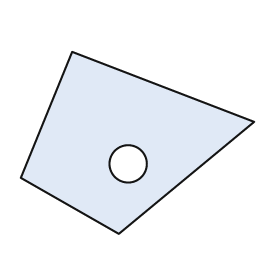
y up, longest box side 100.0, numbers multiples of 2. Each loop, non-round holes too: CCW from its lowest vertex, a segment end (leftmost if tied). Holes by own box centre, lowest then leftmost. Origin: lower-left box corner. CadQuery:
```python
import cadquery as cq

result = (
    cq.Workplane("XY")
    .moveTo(42.0, 0.0)
    .lineTo(100.0, 48.0)
    .lineTo(22.0, 78.0)
    .lineTo(0.0, 24.0)
    .close()
    .moveTo(46.0, 30.0)
    .circle(8.0)
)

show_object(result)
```